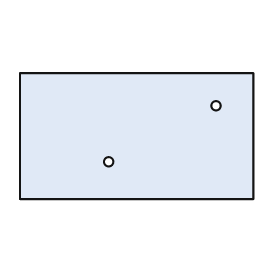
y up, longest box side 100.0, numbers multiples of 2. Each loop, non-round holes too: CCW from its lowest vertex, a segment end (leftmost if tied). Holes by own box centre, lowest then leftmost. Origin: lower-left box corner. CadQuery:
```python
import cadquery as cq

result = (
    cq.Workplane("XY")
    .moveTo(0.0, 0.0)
    .lineTo(100.0, 0.0)
    .lineTo(100.0, 54.0)
    .lineTo(0.0, 54.0)
    .close()
    .moveTo(38.0, 16.0)
    .circle(2.0)
    .moveTo(84.0, 40.0)
    .circle(2.0)
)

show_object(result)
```